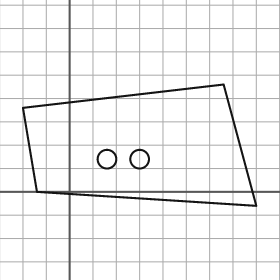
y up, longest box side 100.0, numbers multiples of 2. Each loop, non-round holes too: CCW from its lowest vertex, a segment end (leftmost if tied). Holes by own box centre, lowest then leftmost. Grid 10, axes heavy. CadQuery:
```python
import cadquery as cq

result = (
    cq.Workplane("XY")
    .moveTo(80.0, -6.0)
    .lineTo(66.0, 46.0)
    .lineTo(-20.0, 36.0)
    .lineTo(-14.0, 0.0)
    .close()
    .moveTo(16.0, 14.0)
    .circle(4.0)
    .moveTo(30.0, 14.0)
    .circle(4.0)
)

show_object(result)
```